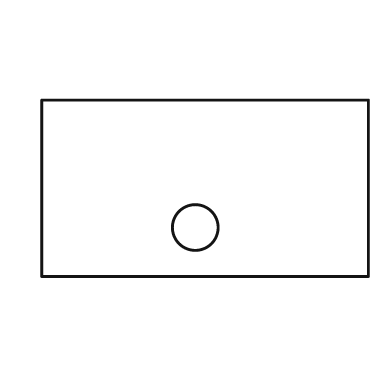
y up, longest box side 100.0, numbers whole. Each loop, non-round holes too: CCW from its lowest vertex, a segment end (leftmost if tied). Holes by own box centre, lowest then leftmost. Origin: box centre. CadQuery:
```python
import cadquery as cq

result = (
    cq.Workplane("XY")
    .moveTo(-50.0, -27.0)
    .lineTo(50.0, -27.0)
    .lineTo(50.0, 27.0)
    .lineTo(-50.0, 27.0)
    .close()
    .moveTo(-3.0, -12.0)
    .circle(7.0)
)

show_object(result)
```